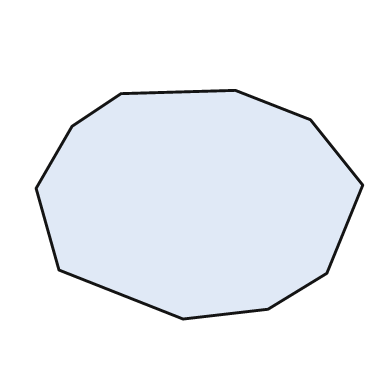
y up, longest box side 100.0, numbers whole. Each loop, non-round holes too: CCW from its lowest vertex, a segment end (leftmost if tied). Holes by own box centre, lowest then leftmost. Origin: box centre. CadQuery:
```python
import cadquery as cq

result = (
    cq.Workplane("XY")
    .moveTo(-5.0, -35.0)
    .lineTo(21.0, -32.0)
    .lineTo(39.0, -21.0)
    .lineTo(50.0, 6.0)
    .lineTo(34.0, 26.0)
    .lineTo(11.0, 35.0)
    .lineTo(-24.0, 34.0)
    .lineTo(-39.0, 24.0)
    .lineTo(-50.0, 5.0)
    .lineTo(-43.0, -20.0)
    .close()
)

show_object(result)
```